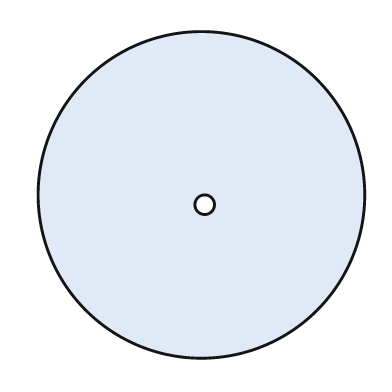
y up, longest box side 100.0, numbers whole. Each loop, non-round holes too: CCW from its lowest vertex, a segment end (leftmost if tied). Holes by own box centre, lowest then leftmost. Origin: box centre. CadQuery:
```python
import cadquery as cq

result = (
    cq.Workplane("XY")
    .moveTo(0.0, 0.0)
    .circle(50.0)
    .moveTo(1.0, -3.0)
    .circle(3.0)
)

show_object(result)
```